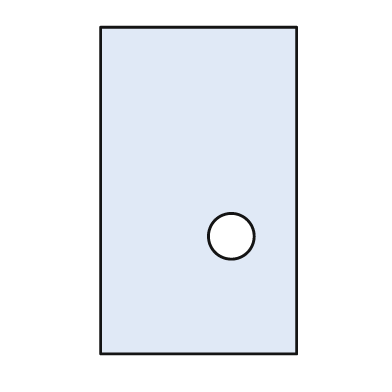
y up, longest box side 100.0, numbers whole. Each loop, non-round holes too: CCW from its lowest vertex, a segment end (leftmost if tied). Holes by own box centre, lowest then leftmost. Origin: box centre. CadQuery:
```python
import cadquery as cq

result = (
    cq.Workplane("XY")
    .moveTo(-30.0, -50.0)
    .lineTo(30.0, -50.0)
    .lineTo(30.0, 50.0)
    .lineTo(-30.0, 50.0)
    .close()
    .moveTo(10.0, -14.0)
    .circle(7.0)
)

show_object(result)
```